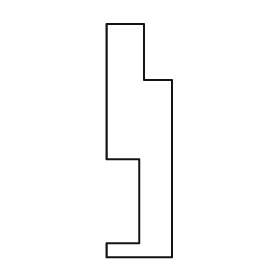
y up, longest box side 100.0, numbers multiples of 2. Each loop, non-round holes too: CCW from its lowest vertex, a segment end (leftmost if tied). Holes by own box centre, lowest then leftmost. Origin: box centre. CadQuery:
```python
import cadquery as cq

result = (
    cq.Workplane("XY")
    .moveTo(-14.0, -50.0)
    .lineTo(14.0, -50.0)
    .lineTo(14.0, 26.0)
    .lineTo(2.0, 26.0)
    .lineTo(2.0, 50.0)
    .lineTo(-14.0, 50.0)
    .lineTo(-14.0, -8.0)
    .lineTo(0.0, -8.0)
    .lineTo(0.0, -44.0)
    .lineTo(-14.0, -44.0)
    .close()
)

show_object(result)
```